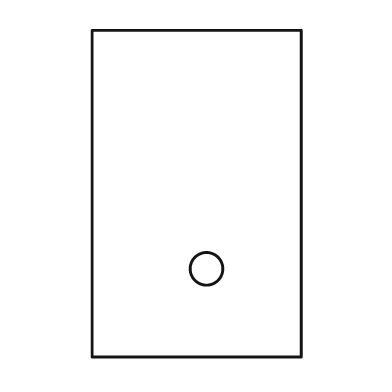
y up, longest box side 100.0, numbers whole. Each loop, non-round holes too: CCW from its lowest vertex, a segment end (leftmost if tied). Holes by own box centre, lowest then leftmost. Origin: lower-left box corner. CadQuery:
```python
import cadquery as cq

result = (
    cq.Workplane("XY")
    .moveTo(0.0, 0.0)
    .lineTo(64.0, 0.0)
    .lineTo(64.0, 100.0)
    .lineTo(0.0, 100.0)
    .close()
    .moveTo(35.0, 27.0)
    .circle(5.0)
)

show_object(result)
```